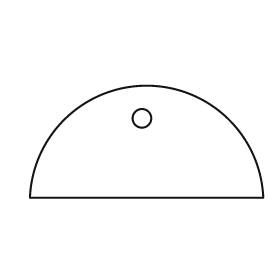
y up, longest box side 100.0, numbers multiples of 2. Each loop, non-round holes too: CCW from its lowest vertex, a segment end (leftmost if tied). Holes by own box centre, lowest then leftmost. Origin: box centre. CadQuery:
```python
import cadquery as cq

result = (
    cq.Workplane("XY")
    .moveTo(-50.0, -24.0)
    .lineTo(50.0, -24.0)
    .threePointArc((0.0, 24.0), (-50.0, -24.0))
    .close()
    .moveTo(-2.0, 10.0)
    .circle(4.0)
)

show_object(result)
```